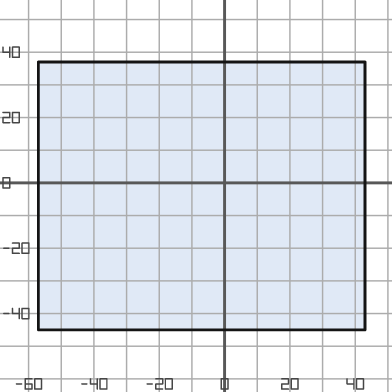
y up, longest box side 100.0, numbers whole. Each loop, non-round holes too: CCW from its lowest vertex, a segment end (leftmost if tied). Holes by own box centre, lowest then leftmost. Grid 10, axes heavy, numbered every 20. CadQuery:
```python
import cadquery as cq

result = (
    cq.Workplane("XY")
    .moveTo(-57.0, -45.0)
    .lineTo(43.0, -45.0)
    .lineTo(43.0, 37.0)
    .lineTo(-57.0, 37.0)
    .close()
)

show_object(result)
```